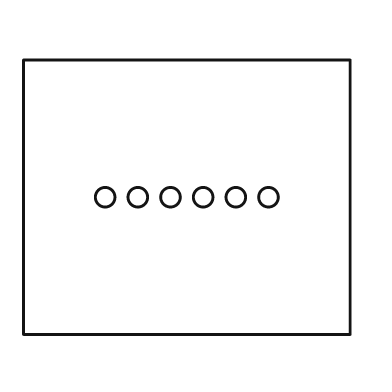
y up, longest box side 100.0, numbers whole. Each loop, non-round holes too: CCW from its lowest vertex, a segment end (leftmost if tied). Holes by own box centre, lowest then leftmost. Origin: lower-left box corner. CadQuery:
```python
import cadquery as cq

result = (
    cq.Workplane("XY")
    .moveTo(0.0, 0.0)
    .lineTo(100.0, 0.0)
    .lineTo(100.0, 84.0)
    .lineTo(0.0, 84.0)
    .close()
    .moveTo(25.0, 42.0)
    .circle(3.0)
    .moveTo(35.0, 42.0)
    .circle(3.0)
    .moveTo(45.0, 42.0)
    .circle(3.0)
    .moveTo(55.0, 42.0)
    .circle(3.0)
    .moveTo(65.0, 42.0)
    .circle(3.0)
    .moveTo(75.0, 42.0)
    .circle(3.0)
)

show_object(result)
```